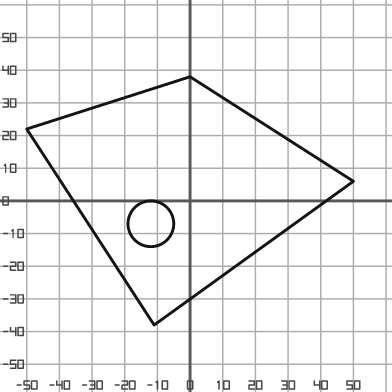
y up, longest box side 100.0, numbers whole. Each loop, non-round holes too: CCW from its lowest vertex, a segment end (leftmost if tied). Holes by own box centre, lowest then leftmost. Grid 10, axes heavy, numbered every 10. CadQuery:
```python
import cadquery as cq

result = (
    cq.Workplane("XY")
    .moveTo(-11.0, -38.0)
    .lineTo(50.0, 6.0)
    .lineTo(0.0, 38.0)
    .lineTo(-50.0, 22.0)
    .close()
    .moveTo(-12.0, -7.0)
    .circle(7.0)
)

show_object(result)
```